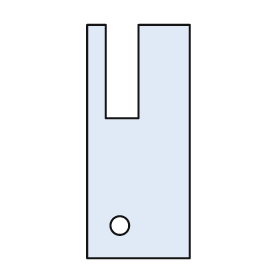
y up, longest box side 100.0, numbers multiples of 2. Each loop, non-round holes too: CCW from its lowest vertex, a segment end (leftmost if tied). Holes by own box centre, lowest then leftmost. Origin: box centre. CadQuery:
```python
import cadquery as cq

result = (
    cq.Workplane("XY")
    .moveTo(-22.0, -50.0)
    .lineTo(22.0, -50.0)
    .lineTo(22.0, 50.0)
    .lineTo(0.0, 50.0)
    .lineTo(0.0, 10.0)
    .lineTo(-14.0, 10.0)
    .lineTo(-14.0, 50.0)
    .lineTo(-22.0, 50.0)
    .close()
    .moveTo(-8.0, -36.0)
    .circle(4.0)
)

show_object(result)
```